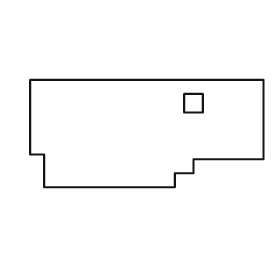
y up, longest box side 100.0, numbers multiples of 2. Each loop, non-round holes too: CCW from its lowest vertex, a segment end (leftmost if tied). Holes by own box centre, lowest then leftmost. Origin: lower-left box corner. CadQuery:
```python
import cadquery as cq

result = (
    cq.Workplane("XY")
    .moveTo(6.0, 0.0)
    .lineTo(62.0, 0.0)
    .lineTo(62.0, 6.0)
    .lineTo(70.0, 6.0)
    .lineTo(70.0, 12.0)
    .lineTo(100.0, 12.0)
    .lineTo(100.0, 46.0)
    .lineTo(0.0, 46.0)
    .lineTo(0.0, 14.0)
    .lineTo(6.0, 14.0)
    .close()
    .moveTo(66.0, 32.0)
    .lineTo(74.0, 32.0)
    .lineTo(74.0, 40.0)
    .lineTo(66.0, 40.0)
    .close()
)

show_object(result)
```